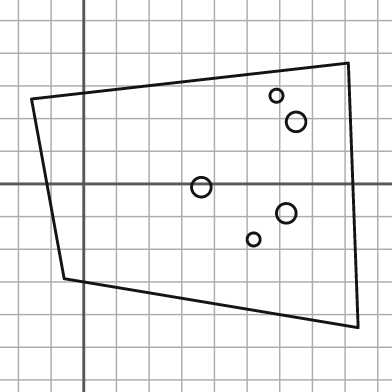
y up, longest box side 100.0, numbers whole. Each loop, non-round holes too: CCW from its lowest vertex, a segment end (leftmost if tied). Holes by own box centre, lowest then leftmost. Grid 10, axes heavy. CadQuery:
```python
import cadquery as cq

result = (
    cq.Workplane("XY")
    .moveTo(84.0, -44.0)
    .lineTo(81.0, 37.0)
    .lineTo(-16.0, 26.0)
    .lineTo(-6.0, -29.0)
    .close()
    .moveTo(52.0, -17.0)
    .circle(2.0)
    .moveTo(62.0, -9.0)
    .circle(3.0)
    .moveTo(36.0, -1.0)
    .circle(3.0)
    .moveTo(65.0, 19.0)
    .circle(3.0)
    .moveTo(59.0, 27.0)
    .circle(2.0)
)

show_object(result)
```